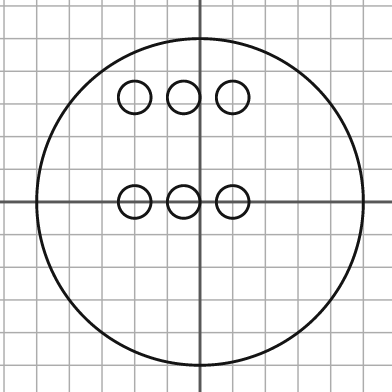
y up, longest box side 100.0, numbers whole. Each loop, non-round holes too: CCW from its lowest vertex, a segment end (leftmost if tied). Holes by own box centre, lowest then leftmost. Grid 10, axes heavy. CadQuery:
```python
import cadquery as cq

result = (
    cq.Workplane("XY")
    .moveTo(0.0, 0.0)
    .circle(50.0)
    .moveTo(-20.0, 0.0)
    .circle(5.0)
    .moveTo(-5.0, 0.0)
    .circle(5.0)
    .moveTo(10.0, 0.0)
    .circle(5.0)
    .moveTo(-20.0, 32.0)
    .circle(5.0)
    .moveTo(-5.0, 32.0)
    .circle(5.0)
    .moveTo(10.0, 32.0)
    .circle(5.0)
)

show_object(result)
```